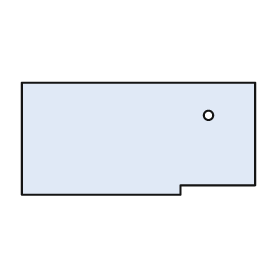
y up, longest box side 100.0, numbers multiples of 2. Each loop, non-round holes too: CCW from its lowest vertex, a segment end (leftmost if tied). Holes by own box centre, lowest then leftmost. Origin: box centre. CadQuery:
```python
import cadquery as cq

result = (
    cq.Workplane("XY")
    .moveTo(-50.0, -24.0)
    .lineTo(18.0, -24.0)
    .lineTo(18.0, -20.0)
    .lineTo(50.0, -20.0)
    .lineTo(50.0, 24.0)
    .lineTo(-50.0, 24.0)
    .close()
    .moveTo(30.0, 10.0)
    .circle(2.0)
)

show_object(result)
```